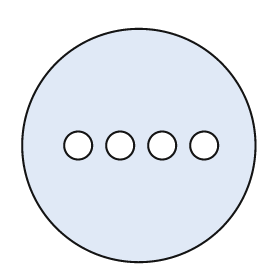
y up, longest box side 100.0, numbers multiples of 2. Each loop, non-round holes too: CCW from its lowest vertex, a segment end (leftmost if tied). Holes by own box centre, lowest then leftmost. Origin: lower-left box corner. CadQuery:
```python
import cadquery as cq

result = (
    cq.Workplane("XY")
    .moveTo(50.0, 50.0)
    .circle(50.0)
    .moveTo(24.0, 50.0)
    .circle(6.0)
    .moveTo(42.0, 50.0)
    .circle(6.0)
    .moveTo(60.0, 50.0)
    .circle(6.0)
    .moveTo(78.0, 50.0)
    .circle(6.0)
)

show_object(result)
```